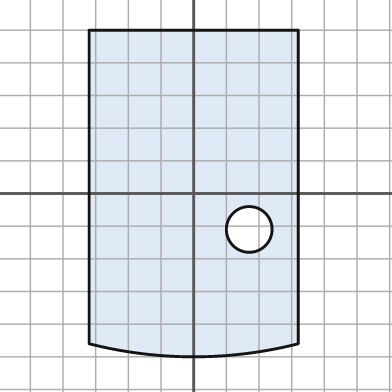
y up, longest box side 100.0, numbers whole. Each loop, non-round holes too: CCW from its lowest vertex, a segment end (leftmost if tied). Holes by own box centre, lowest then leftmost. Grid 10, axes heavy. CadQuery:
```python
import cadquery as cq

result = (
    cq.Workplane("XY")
    .moveTo(-32.0, -46.0)
    .threePointArc((0.0, -50.0), (32.0, -46.0))
    .lineTo(32.0, 50.0)
    .lineTo(-32.0, 50.0)
    .close()
    .moveTo(17.0, -11.0)
    .circle(7.0)
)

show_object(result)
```